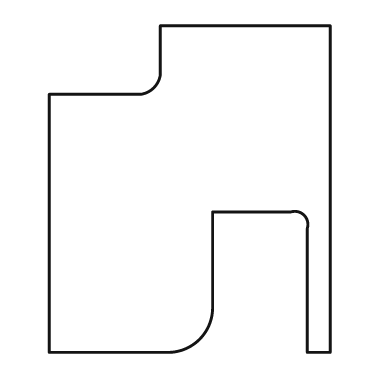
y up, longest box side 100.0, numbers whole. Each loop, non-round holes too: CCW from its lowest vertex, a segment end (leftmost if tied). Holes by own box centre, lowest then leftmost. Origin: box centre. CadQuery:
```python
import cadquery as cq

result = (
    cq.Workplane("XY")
    .moveTo(-43.0, -50.0)
    .lineTo(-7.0, -50.0)
    .threePointArc((3.0, -46.0), (7.0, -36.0))
    .lineTo(7.0, -7.0)
    .lineTo(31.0, -7.0)
    .threePointArc((35.0, -8.0), (36.0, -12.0))
    .lineTo(36.0, -50.0)
    .lineTo(43.0, -50.0)
    .lineTo(43.0, 50.0)
    .lineTo(-9.0, 50.0)
    .lineTo(-9.0, 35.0)
    .threePointArc((-11.0, 31.0), (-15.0, 29.0))
    .lineTo(-43.0, 29.0)
    .close()
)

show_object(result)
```